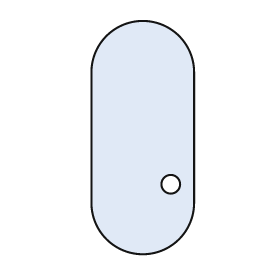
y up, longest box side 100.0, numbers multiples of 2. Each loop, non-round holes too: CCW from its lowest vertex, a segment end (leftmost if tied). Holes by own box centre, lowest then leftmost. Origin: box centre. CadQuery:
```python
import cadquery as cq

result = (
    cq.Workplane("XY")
    .moveTo(-22.0, -28.0)
    .threePointArc((0.0, -50.0), (22.0, -28.0))
    .lineTo(22.0, 28.0)
    .threePointArc((0.0, 50.0), (-22.0, 28.0))
    .close()
    .moveTo(12.0, -20.0)
    .circle(4.0)
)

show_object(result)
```